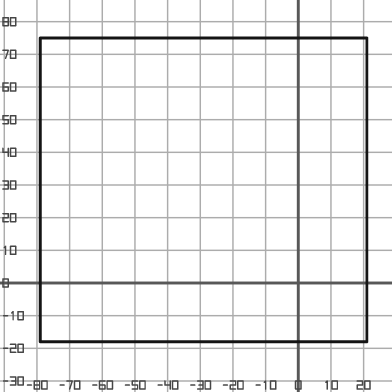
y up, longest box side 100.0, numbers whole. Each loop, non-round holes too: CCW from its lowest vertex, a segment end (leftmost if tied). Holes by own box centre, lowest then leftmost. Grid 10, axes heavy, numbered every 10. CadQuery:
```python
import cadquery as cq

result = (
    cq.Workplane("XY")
    .moveTo(-79.0, -18.0)
    .lineTo(21.0, -18.0)
    .lineTo(21.0, 75.0)
    .lineTo(-79.0, 75.0)
    .close()
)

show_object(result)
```